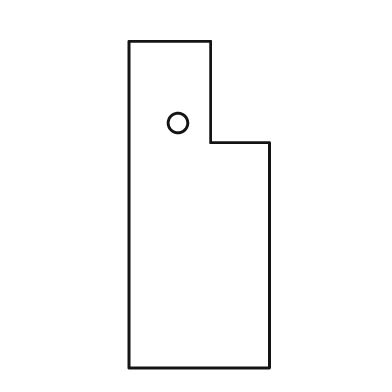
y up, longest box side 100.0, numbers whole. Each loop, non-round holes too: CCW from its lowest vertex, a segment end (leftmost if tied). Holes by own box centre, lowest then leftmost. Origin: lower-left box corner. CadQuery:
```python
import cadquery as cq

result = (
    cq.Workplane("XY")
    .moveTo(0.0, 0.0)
    .lineTo(43.0, 0.0)
    .lineTo(43.0, 69.0)
    .lineTo(25.0, 69.0)
    .lineTo(25.0, 100.0)
    .lineTo(0.0, 100.0)
    .close()
    .moveTo(15.0, 75.0)
    .circle(3.0)
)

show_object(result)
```